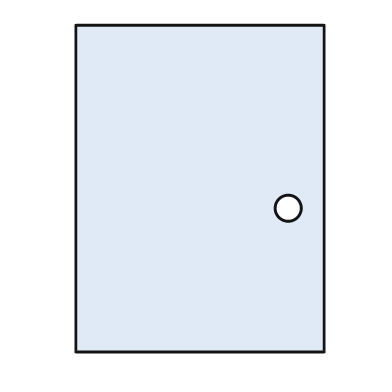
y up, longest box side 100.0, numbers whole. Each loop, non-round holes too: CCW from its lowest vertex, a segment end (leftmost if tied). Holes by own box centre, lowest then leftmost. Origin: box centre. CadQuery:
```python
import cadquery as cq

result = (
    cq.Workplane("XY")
    .moveTo(-38.0, -50.0)
    .lineTo(38.0, -50.0)
    .lineTo(38.0, 50.0)
    .lineTo(-38.0, 50.0)
    .close()
    .moveTo(27.0, -6.0)
    .circle(4.0)
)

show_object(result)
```